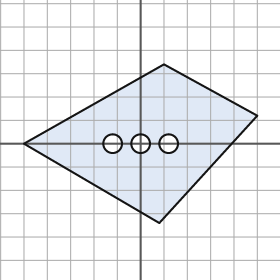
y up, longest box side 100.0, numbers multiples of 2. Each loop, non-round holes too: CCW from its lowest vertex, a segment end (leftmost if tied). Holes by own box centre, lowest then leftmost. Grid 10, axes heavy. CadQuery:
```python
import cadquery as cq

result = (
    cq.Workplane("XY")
    .moveTo(8.0, -34.0)
    .lineTo(50.0, 12.0)
    .lineTo(10.0, 34.0)
    .lineTo(-50.0, 0.0)
    .close()
    .moveTo(-12.0, 0.0)
    .circle(4.0)
    .moveTo(0.0, 0.0)
    .circle(4.0)
    .moveTo(12.0, 0.0)
    .circle(4.0)
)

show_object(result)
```